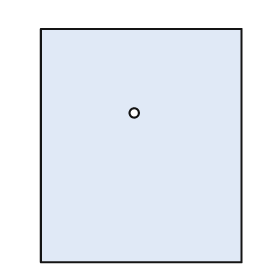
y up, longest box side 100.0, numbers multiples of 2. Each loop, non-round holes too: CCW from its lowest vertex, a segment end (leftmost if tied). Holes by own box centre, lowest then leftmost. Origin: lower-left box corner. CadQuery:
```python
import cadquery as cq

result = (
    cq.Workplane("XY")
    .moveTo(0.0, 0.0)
    .lineTo(86.0, 0.0)
    .lineTo(86.0, 100.0)
    .lineTo(0.0, 100.0)
    .close()
    .moveTo(40.0, 64.0)
    .circle(2.0)
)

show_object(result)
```